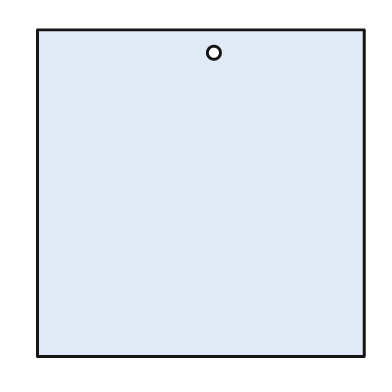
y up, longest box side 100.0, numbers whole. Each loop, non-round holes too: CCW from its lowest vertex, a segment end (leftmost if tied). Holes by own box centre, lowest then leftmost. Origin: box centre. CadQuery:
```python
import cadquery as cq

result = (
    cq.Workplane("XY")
    .moveTo(-50.0, -50.0)
    .lineTo(50.0, -50.0)
    .lineTo(50.0, 50.0)
    .lineTo(-50.0, 50.0)
    .close()
    .moveTo(4.0, 43.0)
    .circle(2.0)
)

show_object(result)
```